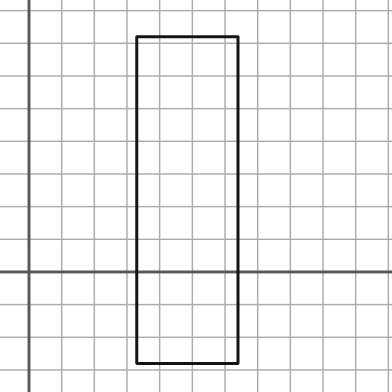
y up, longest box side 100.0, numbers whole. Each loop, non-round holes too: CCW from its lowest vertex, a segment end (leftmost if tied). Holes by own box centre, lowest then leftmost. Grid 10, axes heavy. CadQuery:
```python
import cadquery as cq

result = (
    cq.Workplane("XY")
    .moveTo(33.0, -28.0)
    .lineTo(64.0, -28.0)
    .lineTo(64.0, 72.0)
    .lineTo(33.0, 72.0)
    .close()
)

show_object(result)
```